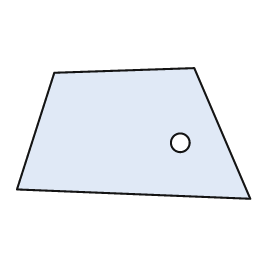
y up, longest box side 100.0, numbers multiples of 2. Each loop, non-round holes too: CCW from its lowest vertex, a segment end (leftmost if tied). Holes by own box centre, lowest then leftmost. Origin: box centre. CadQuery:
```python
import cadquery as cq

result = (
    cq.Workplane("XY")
    .moveTo(50.0, -28.0)
    .lineTo(26.0, 28.0)
    .lineTo(-34.0, 26.0)
    .lineTo(-50.0, -24.0)
    .close()
    .moveTo(20.0, -4.0)
    .circle(4.0)
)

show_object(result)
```